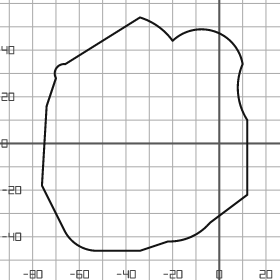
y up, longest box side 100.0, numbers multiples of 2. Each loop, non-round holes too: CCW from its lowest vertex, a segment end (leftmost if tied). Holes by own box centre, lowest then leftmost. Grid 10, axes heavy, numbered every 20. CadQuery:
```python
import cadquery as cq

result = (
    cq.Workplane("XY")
    .moveTo(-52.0, -46.0)
    .lineTo(-34.0, -46.0)
    .lineTo(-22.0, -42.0)
    .threePointArc((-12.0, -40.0), (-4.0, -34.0))
    .lineTo(12.0, -22.0)
    .lineTo(12.0, 10.0)
    .threePointArc((8.0, 22.0), (10.0, 34.0))
    .threePointArc((-2.0, 48.0), (-20.0, 44.0))
    .threePointArc((-26.0, 50.0), (-34.0, 54.0))
    .lineTo(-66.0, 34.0)
    .threePointArc((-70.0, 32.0), (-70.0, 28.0))
    .lineTo(-74.0, 16.0)
    .lineTo(-76.0, -18.0)
    .lineTo(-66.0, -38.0)
    .threePointArc((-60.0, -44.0), (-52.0, -46.0))
    .close()
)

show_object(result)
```